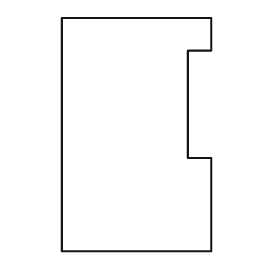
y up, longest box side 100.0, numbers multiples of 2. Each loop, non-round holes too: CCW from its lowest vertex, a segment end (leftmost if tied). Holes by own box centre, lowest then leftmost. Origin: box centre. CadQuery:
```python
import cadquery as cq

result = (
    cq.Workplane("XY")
    .moveTo(-32.0, -50.0)
    .lineTo(32.0, -50.0)
    .lineTo(32.0, -10.0)
    .lineTo(22.0, -10.0)
    .lineTo(22.0, 36.0)
    .lineTo(32.0, 36.0)
    .lineTo(32.0, 50.0)
    .lineTo(-32.0, 50.0)
    .close()
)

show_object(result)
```